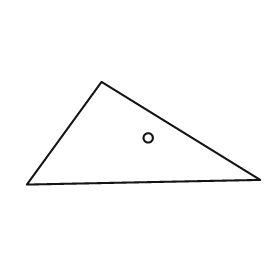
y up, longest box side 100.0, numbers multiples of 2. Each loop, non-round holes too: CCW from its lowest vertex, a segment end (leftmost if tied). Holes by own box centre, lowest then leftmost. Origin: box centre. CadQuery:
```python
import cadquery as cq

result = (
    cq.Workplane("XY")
    .moveTo(-50.0, -22.0)
    .lineTo(50.0, -20.0)
    .lineTo(-18.0, 22.0)
    .close()
    .moveTo(2.0, -2.0)
    .circle(2.0)
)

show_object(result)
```